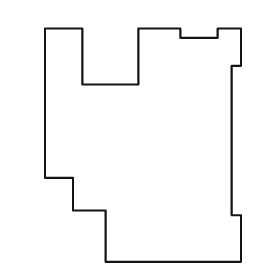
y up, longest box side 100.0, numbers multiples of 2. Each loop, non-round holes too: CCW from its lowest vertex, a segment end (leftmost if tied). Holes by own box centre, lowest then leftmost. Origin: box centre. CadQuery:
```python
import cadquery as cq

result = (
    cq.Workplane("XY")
    .moveTo(-16.0, -50.0)
    .lineTo(42.0, -50.0)
    .lineTo(42.0, -30.0)
    .lineTo(38.0, -30.0)
    .lineTo(38.0, 34.0)
    .lineTo(42.0, 34.0)
    .lineTo(42.0, 50.0)
    .lineTo(32.0, 50.0)
    .lineTo(32.0, 46.0)
    .lineTo(16.0, 46.0)
    .lineTo(16.0, 50.0)
    .lineTo(-2.0, 50.0)
    .lineTo(-2.0, 26.0)
    .lineTo(-26.0, 26.0)
    .lineTo(-26.0, 50.0)
    .lineTo(-42.0, 50.0)
    .lineTo(-42.0, -14.0)
    .lineTo(-30.0, -14.0)
    .lineTo(-30.0, -28.0)
    .lineTo(-16.0, -28.0)
    .close()
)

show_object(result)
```